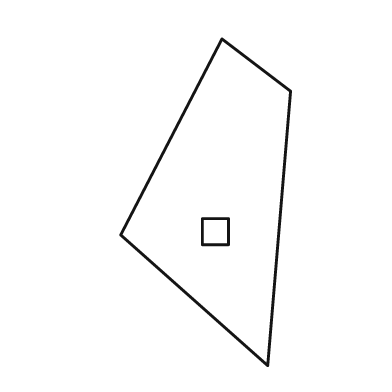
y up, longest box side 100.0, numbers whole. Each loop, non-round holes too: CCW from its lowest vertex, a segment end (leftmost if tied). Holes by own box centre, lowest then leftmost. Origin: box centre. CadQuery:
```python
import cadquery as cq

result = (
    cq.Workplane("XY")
    .moveTo(19.0, -50.0)
    .lineTo(26.0, 34.0)
    .lineTo(5.0, 50.0)
    .lineTo(-26.0, -10.0)
    .close()
    .moveTo(-1.0, -13.0)
    .lineTo(7.0, -13.0)
    .lineTo(7.0, -5.0)
    .lineTo(-1.0, -5.0)
    .close()
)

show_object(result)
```